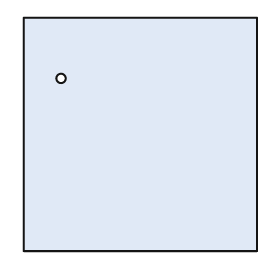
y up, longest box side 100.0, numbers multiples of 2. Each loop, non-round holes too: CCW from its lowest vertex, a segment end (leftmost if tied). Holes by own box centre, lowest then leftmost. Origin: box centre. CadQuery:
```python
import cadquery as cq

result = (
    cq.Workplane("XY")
    .moveTo(-50.0, -50.0)
    .lineTo(50.0, -50.0)
    .lineTo(50.0, 50.0)
    .lineTo(-50.0, 50.0)
    .close()
    .moveTo(-34.0, 24.0)
    .circle(2.0)
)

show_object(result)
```